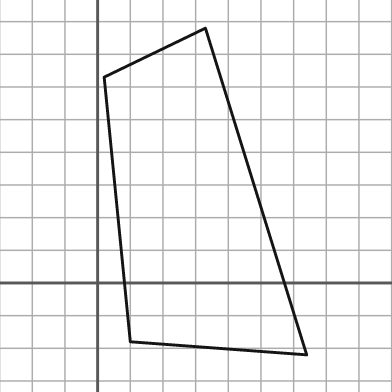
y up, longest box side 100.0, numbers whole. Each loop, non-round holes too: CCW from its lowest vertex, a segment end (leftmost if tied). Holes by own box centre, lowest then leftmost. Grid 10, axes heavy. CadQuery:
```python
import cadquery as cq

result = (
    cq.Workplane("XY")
    .moveTo(64.0, -22.0)
    .lineTo(33.0, 78.0)
    .lineTo(2.0, 63.0)
    .lineTo(10.0, -18.0)
    .close()
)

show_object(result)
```